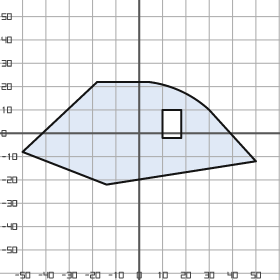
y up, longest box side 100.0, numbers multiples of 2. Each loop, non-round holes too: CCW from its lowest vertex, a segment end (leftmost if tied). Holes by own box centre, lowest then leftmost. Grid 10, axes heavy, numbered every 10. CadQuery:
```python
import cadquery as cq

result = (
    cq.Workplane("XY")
    .moveTo(-14.0, -22.0)
    .lineTo(50.0, -12.0)
    .lineTo(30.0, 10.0)
    .threePointArc((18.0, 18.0), (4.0, 22.0))
    .lineTo(-18.0, 22.0)
    .lineTo(-50.0, -8.0)
    .close()
    .moveTo(10.0, -2.0)
    .lineTo(18.0, -2.0)
    .lineTo(18.0, 10.0)
    .lineTo(10.0, 10.0)
    .close()
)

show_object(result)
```